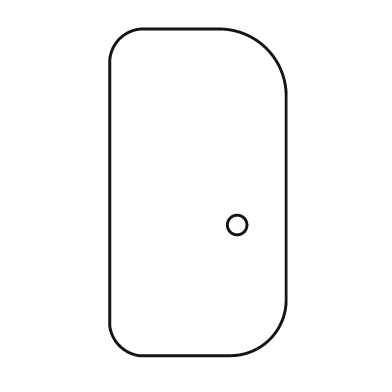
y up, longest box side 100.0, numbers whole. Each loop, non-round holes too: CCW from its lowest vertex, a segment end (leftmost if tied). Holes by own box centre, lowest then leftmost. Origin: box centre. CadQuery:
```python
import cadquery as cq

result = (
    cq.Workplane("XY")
    .moveTo(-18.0, -50.0)
    .lineTo(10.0, -50.0)
    .threePointArc((22.0, -45.0), (27.0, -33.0))
    .lineTo(27.0, 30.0)
    .threePointArc((21.0, 44.0), (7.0, 50.0))
    .lineTo(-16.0, 50.0)
    .threePointArc((-24.0, 47.0), (-27.0, 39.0))
    .lineTo(-27.0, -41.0)
    .threePointArc((-24.0, -47.0), (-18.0, -50.0))
    .close()
    .moveTo(12.0, -10.0)
    .circle(3.0)
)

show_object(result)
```